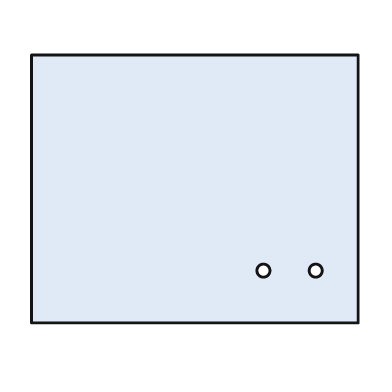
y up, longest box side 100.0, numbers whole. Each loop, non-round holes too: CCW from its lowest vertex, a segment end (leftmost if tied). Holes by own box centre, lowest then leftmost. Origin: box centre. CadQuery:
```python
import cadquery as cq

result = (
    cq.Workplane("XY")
    .moveTo(-50.0, -41.0)
    .lineTo(50.0, -41.0)
    .lineTo(50.0, 41.0)
    .lineTo(-50.0, 41.0)
    .close()
    .moveTo(21.0, -25.0)
    .circle(2.0)
    .moveTo(37.0, -25.0)
    .circle(2.0)
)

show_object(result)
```